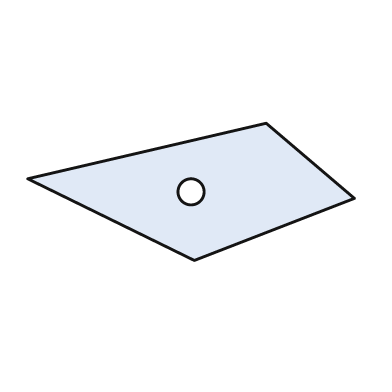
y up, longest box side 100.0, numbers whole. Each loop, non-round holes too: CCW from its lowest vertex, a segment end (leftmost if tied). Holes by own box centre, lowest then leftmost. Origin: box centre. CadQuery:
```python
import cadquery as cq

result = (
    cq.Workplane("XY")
    .moveTo(1.0, -21.0)
    .lineTo(50.0, -2.0)
    .lineTo(23.0, 21.0)
    .lineTo(-50.0, 4.0)
    .close()
    .moveTo(0.0, 0.0)
    .circle(4.0)
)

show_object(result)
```